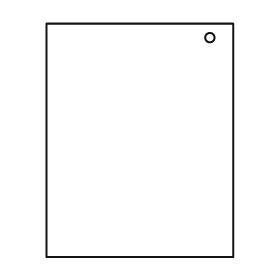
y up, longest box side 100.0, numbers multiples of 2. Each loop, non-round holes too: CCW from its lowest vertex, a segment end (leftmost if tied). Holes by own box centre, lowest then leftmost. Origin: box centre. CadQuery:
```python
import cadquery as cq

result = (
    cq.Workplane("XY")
    .moveTo(-40.0, -50.0)
    .lineTo(40.0, -50.0)
    .lineTo(40.0, 50.0)
    .lineTo(-40.0, 50.0)
    .close()
    .moveTo(30.0, 44.0)
    .circle(2.0)
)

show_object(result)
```